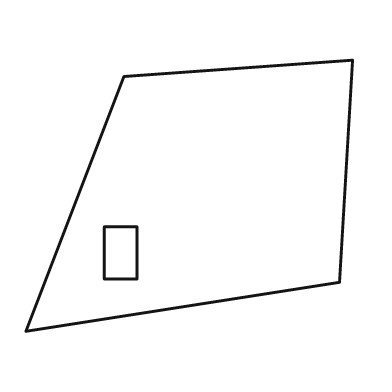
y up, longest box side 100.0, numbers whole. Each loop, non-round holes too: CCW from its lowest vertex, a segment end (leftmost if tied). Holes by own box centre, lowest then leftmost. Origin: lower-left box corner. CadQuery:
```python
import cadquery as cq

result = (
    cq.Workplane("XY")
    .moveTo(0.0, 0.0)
    .lineTo(96.0, 15.0)
    .lineTo(100.0, 83.0)
    .lineTo(30.0, 78.0)
    .close()
    .moveTo(24.0, 16.0)
    .lineTo(34.0, 16.0)
    .lineTo(34.0, 32.0)
    .lineTo(24.0, 32.0)
    .close()
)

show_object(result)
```